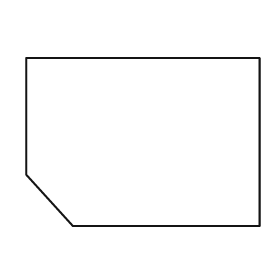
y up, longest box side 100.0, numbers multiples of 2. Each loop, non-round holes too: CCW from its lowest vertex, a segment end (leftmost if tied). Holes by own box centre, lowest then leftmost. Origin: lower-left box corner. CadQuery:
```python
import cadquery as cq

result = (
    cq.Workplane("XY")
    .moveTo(20.0, 0.0)
    .lineTo(100.0, 0.0)
    .lineTo(100.0, 72.0)
    .lineTo(0.0, 72.0)
    .lineTo(0.0, 22.0)
    .close()
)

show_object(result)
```